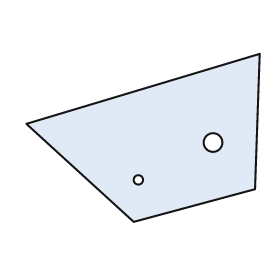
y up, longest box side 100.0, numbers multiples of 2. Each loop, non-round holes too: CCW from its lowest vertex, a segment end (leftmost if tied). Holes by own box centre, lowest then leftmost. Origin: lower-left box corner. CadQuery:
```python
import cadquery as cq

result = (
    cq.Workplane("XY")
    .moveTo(46.0, 0.0)
    .lineTo(98.0, 14.0)
    .lineTo(100.0, 72.0)
    .lineTo(0.0, 42.0)
    .close()
    .moveTo(48.0, 18.0)
    .circle(2.0)
    .moveTo(80.0, 34.0)
    .circle(4.0)
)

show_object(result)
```